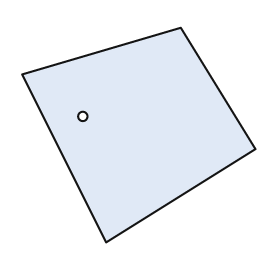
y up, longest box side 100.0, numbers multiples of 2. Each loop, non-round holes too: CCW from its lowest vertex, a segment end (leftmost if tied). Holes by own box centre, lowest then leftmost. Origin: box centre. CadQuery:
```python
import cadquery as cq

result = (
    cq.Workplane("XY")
    .moveTo(-14.0, -46.0)
    .lineTo(50.0, -6.0)
    .lineTo(18.0, 46.0)
    .lineTo(-50.0, 26.0)
    .close()
    .moveTo(-24.0, 8.0)
    .circle(2.0)
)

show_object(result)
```